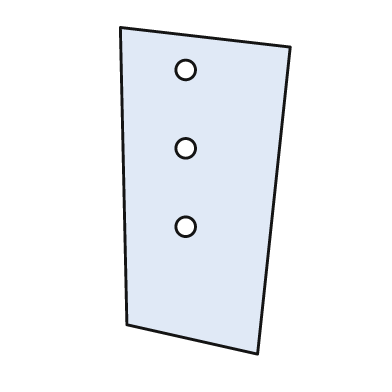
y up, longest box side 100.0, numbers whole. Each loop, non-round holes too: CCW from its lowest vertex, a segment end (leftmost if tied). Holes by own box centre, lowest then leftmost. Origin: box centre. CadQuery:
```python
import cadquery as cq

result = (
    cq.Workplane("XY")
    .moveTo(16.0, -50.0)
    .lineTo(26.0, 44.0)
    .lineTo(-26.0, 50.0)
    .lineTo(-24.0, -41.0)
    .close()
    .moveTo(-6.0, -11.0)
    .circle(3.0)
    .moveTo(-6.0, 13.0)
    .circle(3.0)
    .moveTo(-6.0, 37.0)
    .circle(3.0)
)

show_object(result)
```